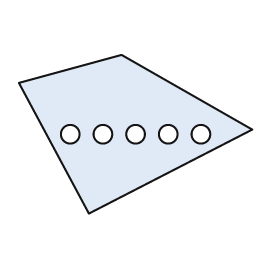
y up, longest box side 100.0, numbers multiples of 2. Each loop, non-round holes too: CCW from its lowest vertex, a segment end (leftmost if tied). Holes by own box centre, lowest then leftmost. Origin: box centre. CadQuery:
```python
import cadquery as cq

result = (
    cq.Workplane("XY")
    .moveTo(-20.0, -34.0)
    .lineTo(50.0, 2.0)
    .lineTo(-6.0, 34.0)
    .lineTo(-50.0, 22.0)
    .close()
    .moveTo(-28.0, 0.0)
    .circle(4.0)
    .moveTo(-14.0, 0.0)
    .circle(4.0)
    .moveTo(0.0, 0.0)
    .circle(4.0)
    .moveTo(14.0, 0.0)
    .circle(4.0)
    .moveTo(28.0, 0.0)
    .circle(4.0)
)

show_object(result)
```